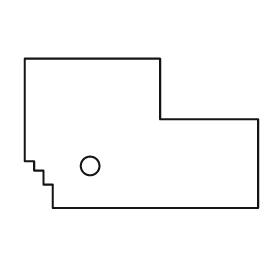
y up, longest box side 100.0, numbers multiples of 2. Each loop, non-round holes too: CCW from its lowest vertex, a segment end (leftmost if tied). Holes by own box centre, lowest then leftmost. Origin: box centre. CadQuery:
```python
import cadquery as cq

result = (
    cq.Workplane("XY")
    .moveTo(-38.0, -32.0)
    .lineTo(50.0, -32.0)
    .lineTo(50.0, 6.0)
    .lineTo(8.0, 6.0)
    .lineTo(8.0, 32.0)
    .lineTo(-50.0, 32.0)
    .lineTo(-50.0, -12.0)
    .lineTo(-46.0, -12.0)
    .lineTo(-46.0, -16.0)
    .lineTo(-42.0, -16.0)
    .lineTo(-42.0, -22.0)
    .lineTo(-38.0, -22.0)
    .close()
    .moveTo(-22.0, -14.0)
    .circle(4.0)
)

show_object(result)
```